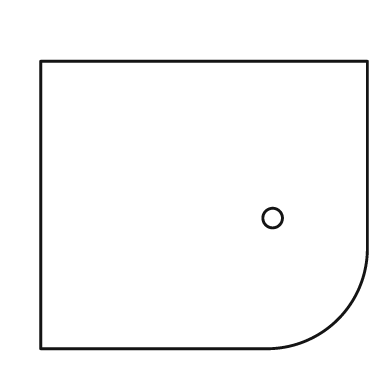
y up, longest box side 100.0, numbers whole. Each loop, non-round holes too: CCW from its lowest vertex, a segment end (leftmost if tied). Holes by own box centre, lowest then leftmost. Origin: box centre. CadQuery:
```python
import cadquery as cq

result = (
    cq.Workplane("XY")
    .moveTo(-50.0, -44.0)
    .lineTo(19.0, -44.0)
    .threePointArc((41.0, -35.0), (50.0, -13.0))
    .lineTo(50.0, 44.0)
    .lineTo(-50.0, 44.0)
    .close()
    .moveTo(21.0, -4.0)
    .circle(3.0)
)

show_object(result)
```